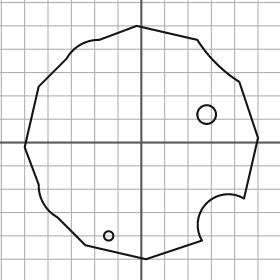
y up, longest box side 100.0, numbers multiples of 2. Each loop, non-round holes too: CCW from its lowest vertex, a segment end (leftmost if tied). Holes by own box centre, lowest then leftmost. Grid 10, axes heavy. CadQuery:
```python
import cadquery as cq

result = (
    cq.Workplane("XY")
    .moveTo(2.0, -50.0)
    .lineTo(26.0, -42.0)
    .threePointArc((28.0, -26.0), (44.0, -24.0))
    .lineTo(50.0, 2.0)
    .lineTo(42.0, 26.0)
    .threePointArc((32.0, 34.0), (24.0, 44.0))
    .lineTo(-2.0, 50.0)
    .lineTo(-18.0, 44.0)
    .threePointArc((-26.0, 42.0), (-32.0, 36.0))
    .lineTo(-44.0, 24.0)
    .lineTo(-50.0, -2.0)
    .lineTo(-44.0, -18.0)
    .threePointArc((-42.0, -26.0), (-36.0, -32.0))
    .lineTo(-24.0, -44.0)
    .close()
    .moveTo(-14.0, -40.0)
    .circle(2.0)
    .moveTo(28.0, 12.0)
    .circle(4.0)
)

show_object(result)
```